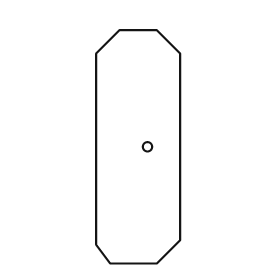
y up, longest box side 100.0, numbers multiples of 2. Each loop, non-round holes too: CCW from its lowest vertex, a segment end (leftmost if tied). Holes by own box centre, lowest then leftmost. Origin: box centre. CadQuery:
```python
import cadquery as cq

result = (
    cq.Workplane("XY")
    .moveTo(-12.0, -50.0)
    .lineTo(8.0, -50.0)
    .lineTo(18.0, -40.0)
    .lineTo(18.0, 40.0)
    .lineTo(8.0, 50.0)
    .lineTo(-8.0, 50.0)
    .lineTo(-18.0, 40.0)
    .lineTo(-18.0, -42.0)
    .close()
    .moveTo(4.0, 0.0)
    .circle(2.0)
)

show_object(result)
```